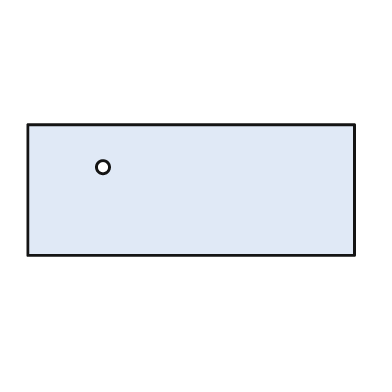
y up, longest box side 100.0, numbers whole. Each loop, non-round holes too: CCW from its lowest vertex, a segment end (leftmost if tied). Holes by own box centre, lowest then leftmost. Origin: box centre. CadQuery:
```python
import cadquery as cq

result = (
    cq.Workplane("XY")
    .moveTo(-50.0, -20.0)
    .lineTo(50.0, -20.0)
    .lineTo(50.0, 20.0)
    .lineTo(-50.0, 20.0)
    .close()
    .moveTo(-27.0, 7.0)
    .circle(2.0)
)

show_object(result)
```